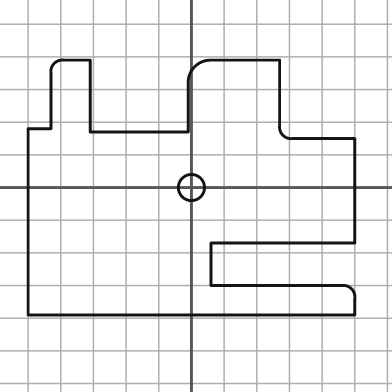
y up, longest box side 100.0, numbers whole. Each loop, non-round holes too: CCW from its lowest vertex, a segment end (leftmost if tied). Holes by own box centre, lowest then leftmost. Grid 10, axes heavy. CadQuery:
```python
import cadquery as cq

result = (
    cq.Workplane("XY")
    .moveTo(-50.0, -39.0)
    .lineTo(50.0, -39.0)
    .lineTo(50.0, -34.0)
    .threePointArc((49.0, -31.0), (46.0, -30.0))
    .lineTo(6.0, -30.0)
    .lineTo(6.0, -17.0)
    .lineTo(50.0, -17.0)
    .lineTo(50.0, 15.0)
    .lineTo(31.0, 15.0)
    .threePointArc((28.0, 16.0), (27.0, 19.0))
    .lineTo(27.0, 39.0)
    .lineTo(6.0, 39.0)
    .threePointArc((1.0, 37.0), (-1.0, 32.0))
    .lineTo(-1.0, 17.0)
    .lineTo(-31.0, 17.0)
    .lineTo(-31.0, 39.0)
    .lineTo(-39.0, 39.0)
    .threePointArc((-42.0, 38.0), (-43.0, 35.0))
    .lineTo(-43.0, 18.0)
    .lineTo(-50.0, 18.0)
    .close()
    .moveTo(0.0, 0.0)
    .circle(4.0)
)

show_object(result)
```